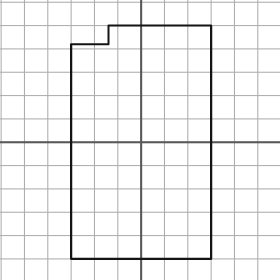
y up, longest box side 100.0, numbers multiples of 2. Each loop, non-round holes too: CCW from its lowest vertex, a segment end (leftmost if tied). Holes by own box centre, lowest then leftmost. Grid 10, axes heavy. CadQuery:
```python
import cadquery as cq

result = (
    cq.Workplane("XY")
    .moveTo(-30.0, -50.0)
    .lineTo(30.0, -50.0)
    .lineTo(30.0, 50.0)
    .lineTo(-14.0, 50.0)
    .lineTo(-14.0, 42.0)
    .lineTo(-30.0, 42.0)
    .close()
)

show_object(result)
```